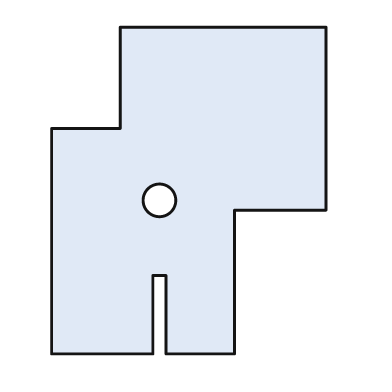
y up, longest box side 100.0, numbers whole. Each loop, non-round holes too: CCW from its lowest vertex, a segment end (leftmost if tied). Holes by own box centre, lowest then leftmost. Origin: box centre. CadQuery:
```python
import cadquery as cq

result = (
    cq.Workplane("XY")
    .moveTo(-42.0, -50.0)
    .lineTo(-11.0, -50.0)
    .lineTo(-11.0, -26.0)
    .lineTo(-7.0, -26.0)
    .lineTo(-7.0, -50.0)
    .lineTo(14.0, -50.0)
    .lineTo(14.0, -6.0)
    .lineTo(42.0, -6.0)
    .lineTo(42.0, 50.0)
    .lineTo(-21.0, 50.0)
    .lineTo(-21.0, 19.0)
    .lineTo(-42.0, 19.0)
    .close()
    .moveTo(-9.0, -3.0)
    .circle(5.0)
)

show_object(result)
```